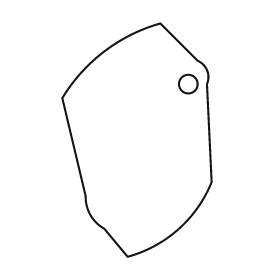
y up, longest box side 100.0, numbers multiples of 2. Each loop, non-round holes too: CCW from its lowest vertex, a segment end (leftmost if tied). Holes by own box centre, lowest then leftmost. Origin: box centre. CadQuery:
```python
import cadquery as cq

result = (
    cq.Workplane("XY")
    .moveTo(-4.0, -50.0)
    .threePointArc((18.0, -38.0), (32.0, -18.0))
    .lineTo(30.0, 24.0)
    .threePointArc((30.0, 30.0), (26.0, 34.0))
    .lineTo(10.0, 50.0)
    .threePointArc((-14.0, 38.0), (-32.0, 18.0))
    .lineTo(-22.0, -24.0)
    .threePointArc((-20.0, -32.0), (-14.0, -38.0))
    .close()
    .moveTo(22.0, 24.0)
    .circle(4.0)
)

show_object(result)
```